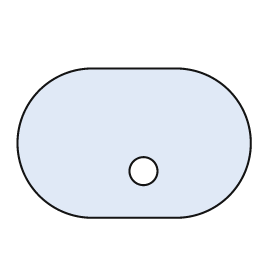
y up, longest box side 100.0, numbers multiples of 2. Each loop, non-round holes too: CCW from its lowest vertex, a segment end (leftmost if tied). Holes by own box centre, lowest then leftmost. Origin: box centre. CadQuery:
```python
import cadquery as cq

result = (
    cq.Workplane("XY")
    .moveTo(-18.0, -32.0)
    .lineTo(18.0, -32.0)
    .threePointArc((50.0, 0.0), (18.0, 32.0))
    .lineTo(-18.0, 32.0)
    .threePointArc((-50.0, 0.0), (-18.0, -32.0))
    .close()
    .moveTo(4.0, -12.0)
    .circle(6.0)
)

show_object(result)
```